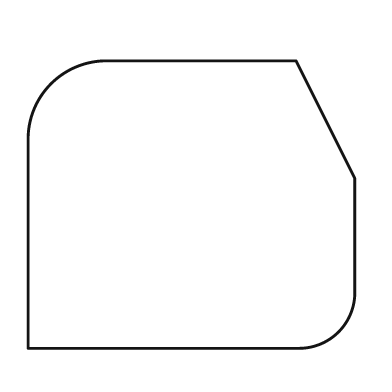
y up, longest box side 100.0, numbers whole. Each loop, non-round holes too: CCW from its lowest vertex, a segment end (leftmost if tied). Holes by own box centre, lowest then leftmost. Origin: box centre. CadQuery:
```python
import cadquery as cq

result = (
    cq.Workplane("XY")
    .moveTo(-50.0, -44.0)
    .lineTo(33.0, -44.0)
    .threePointArc((45.0, -39.0), (50.0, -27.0))
    .lineTo(50.0, 8.0)
    .lineTo(32.0, 44.0)
    .lineTo(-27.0, 44.0)
    .threePointArc((-43.0, 37.0), (-50.0, 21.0))
    .close()
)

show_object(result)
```